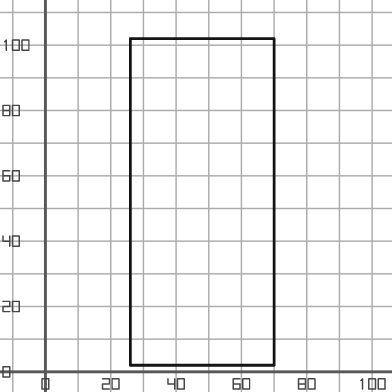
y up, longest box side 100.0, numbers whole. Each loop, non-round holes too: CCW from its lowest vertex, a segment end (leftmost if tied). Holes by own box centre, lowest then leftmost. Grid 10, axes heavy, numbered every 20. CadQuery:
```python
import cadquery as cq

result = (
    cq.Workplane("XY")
    .moveTo(26.0, 2.0)
    .lineTo(70.0, 2.0)
    .lineTo(70.0, 102.0)
    .lineTo(26.0, 102.0)
    .close()
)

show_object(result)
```